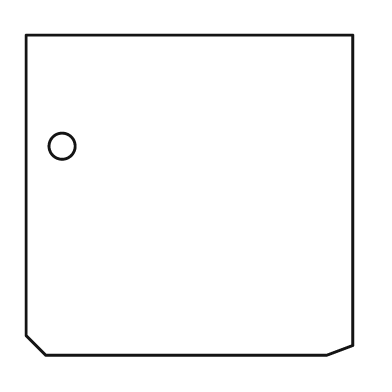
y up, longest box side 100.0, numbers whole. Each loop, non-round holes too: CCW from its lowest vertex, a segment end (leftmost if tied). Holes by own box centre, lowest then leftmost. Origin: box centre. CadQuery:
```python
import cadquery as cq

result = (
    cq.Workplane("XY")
    .moveTo(-44.0, -49.0)
    .lineTo(42.0, -49.0)
    .lineTo(50.0, -46.0)
    .lineTo(50.0, 49.0)
    .lineTo(-50.0, 49.0)
    .lineTo(-50.0, -43.0)
    .close()
    .moveTo(-39.0, 15.0)
    .circle(4.0)
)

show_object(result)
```